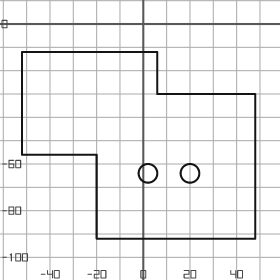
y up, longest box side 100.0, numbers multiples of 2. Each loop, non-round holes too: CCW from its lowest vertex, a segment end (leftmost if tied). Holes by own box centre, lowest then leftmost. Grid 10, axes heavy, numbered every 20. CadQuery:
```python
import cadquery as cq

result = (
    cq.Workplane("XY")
    .moveTo(-20.0, -92.0)
    .lineTo(48.0, -92.0)
    .lineTo(48.0, -30.0)
    .lineTo(6.0, -30.0)
    .lineTo(6.0, -12.0)
    .lineTo(-52.0, -12.0)
    .lineTo(-52.0, -56.0)
    .lineTo(-20.0, -56.0)
    .close()
    .moveTo(2.0, -64.0)
    .circle(4.0)
    .moveTo(20.0, -64.0)
    .circle(4.0)
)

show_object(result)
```